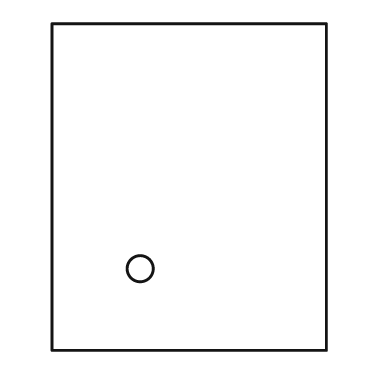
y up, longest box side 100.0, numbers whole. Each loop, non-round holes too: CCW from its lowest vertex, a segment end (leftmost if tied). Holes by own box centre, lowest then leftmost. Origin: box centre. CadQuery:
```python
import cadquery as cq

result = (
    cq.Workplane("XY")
    .moveTo(-42.0, -50.0)
    .lineTo(42.0, -50.0)
    .lineTo(42.0, 50.0)
    .lineTo(-42.0, 50.0)
    .close()
    .moveTo(-15.0, -25.0)
    .circle(4.0)
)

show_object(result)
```